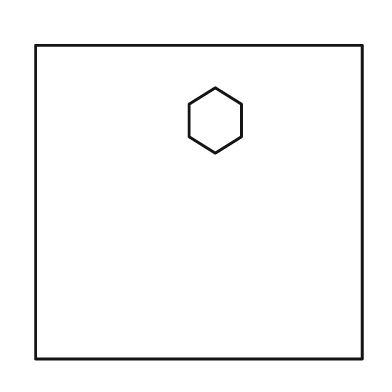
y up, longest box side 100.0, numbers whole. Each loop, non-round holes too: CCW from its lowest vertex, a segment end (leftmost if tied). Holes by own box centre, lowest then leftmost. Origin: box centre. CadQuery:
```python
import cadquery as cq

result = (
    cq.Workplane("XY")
    .moveTo(-50.0, -48.0)
    .lineTo(50.0, -48.0)
    .lineTo(50.0, 48.0)
    .lineTo(-50.0, 48.0)
    .close()
    .moveTo(5.0, 15.0)
    .lineTo(13.0, 20.0)
    .lineTo(13.0, 30.0)
    .lineTo(5.0, 35.0)
    .lineTo(-3.0, 30.0)
    .lineTo(-3.0, 20.0)
    .close()
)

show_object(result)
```